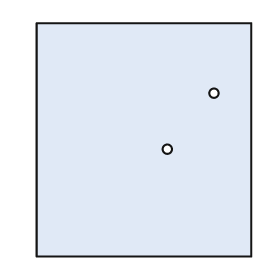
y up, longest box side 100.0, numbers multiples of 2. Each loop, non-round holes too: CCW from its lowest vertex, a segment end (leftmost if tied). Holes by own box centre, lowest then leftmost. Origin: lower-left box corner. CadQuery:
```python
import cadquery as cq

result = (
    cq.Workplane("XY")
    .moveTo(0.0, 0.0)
    .lineTo(92.0, 0.0)
    .lineTo(92.0, 100.0)
    .lineTo(0.0, 100.0)
    .close()
    .moveTo(56.0, 46.0)
    .circle(2.0)
    .moveTo(76.0, 70.0)
    .circle(2.0)
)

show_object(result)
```